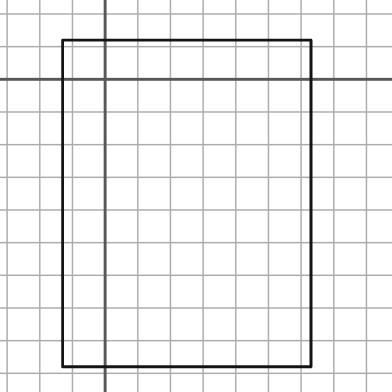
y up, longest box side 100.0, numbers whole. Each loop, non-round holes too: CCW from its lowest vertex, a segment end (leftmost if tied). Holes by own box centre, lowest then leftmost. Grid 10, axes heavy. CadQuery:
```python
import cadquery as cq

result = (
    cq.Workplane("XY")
    .moveTo(-13.0, -88.0)
    .lineTo(63.0, -88.0)
    .lineTo(63.0, 12.0)
    .lineTo(-13.0, 12.0)
    .close()
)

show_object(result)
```